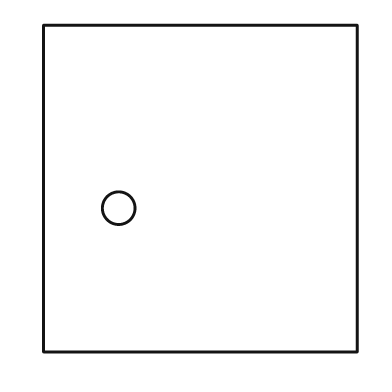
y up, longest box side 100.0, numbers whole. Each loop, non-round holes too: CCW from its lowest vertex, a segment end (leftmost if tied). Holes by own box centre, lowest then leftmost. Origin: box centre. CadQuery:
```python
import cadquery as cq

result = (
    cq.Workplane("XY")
    .moveTo(-48.0, -50.0)
    .lineTo(48.0, -50.0)
    .lineTo(48.0, 50.0)
    .lineTo(-48.0, 50.0)
    .close()
    .moveTo(-25.0, -6.0)
    .circle(5.0)
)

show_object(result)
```